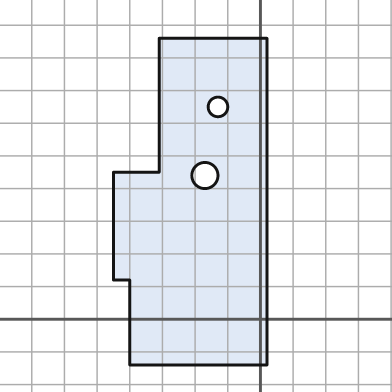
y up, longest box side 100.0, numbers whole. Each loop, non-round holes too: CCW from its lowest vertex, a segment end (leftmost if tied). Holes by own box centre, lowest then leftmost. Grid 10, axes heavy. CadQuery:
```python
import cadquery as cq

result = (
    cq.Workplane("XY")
    .moveTo(-40.0, -14.0)
    .lineTo(2.0, -14.0)
    .lineTo(2.0, 86.0)
    .lineTo(-31.0, 86.0)
    .lineTo(-31.0, 45.0)
    .lineTo(-45.0, 45.0)
    .lineTo(-45.0, 12.0)
    .lineTo(-40.0, 12.0)
    .close()
    .moveTo(-17.0, 44.0)
    .circle(4.0)
    .moveTo(-13.0, 65.0)
    .circle(3.0)
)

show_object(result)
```